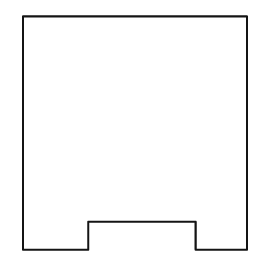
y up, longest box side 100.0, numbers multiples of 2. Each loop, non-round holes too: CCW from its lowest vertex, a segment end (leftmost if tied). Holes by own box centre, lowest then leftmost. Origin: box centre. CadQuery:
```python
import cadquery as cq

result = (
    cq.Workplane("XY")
    .moveTo(-48.0, -50.0)
    .lineTo(-20.0, -50.0)
    .lineTo(-20.0, -38.0)
    .lineTo(26.0, -38.0)
    .lineTo(26.0, -50.0)
    .lineTo(48.0, -50.0)
    .lineTo(48.0, 50.0)
    .lineTo(-48.0, 50.0)
    .close()
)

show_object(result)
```